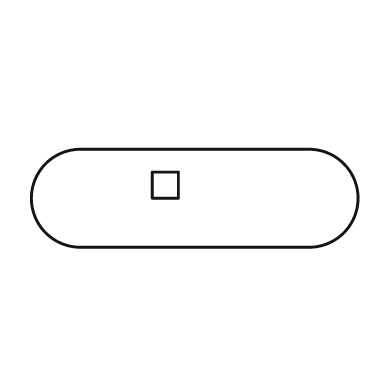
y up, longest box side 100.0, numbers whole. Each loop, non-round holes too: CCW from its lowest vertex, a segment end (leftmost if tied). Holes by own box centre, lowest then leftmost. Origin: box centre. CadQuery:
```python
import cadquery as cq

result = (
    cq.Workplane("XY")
    .moveTo(-35.0, -15.0)
    .lineTo(35.0, -15.0)
    .threePointArc((50.0, 0.0), (35.0, 15.0))
    .lineTo(-35.0, 15.0)
    .threePointArc((-50.0, 0.0), (-35.0, -15.0))
    .close()
    .moveTo(-13.0, 0.0)
    .lineTo(-5.0, 0.0)
    .lineTo(-5.0, 8.0)
    .lineTo(-13.0, 8.0)
    .close()
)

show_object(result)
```